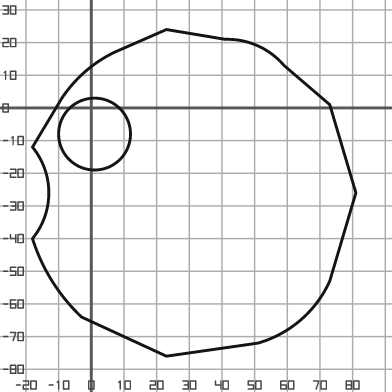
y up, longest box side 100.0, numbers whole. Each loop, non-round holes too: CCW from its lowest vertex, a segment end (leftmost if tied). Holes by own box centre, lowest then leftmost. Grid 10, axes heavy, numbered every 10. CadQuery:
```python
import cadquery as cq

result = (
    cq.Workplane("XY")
    .moveTo(23.0, -76.0)
    .lineTo(51.0, -72.0)
    .threePointArc((64.0, -65.0), (73.0, -53.0))
    .lineTo(81.0, -26.0)
    .lineTo(73.0, 1.0)
    .lineTo(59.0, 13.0)
    .threePointArc((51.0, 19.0), (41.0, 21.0))
    .lineTo(23.0, 24.0)
    .lineTo(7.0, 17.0)
    .threePointArc((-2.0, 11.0), (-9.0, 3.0))
    .lineTo(-18.0, -12.0)
    .threePointArc((-13.0, -26.0), (-18.0, -40.0))
    .threePointArc((-12.0, -53.0), (-3.0, -64.0))
    .close()
    .moveTo(1.0, -8.0)
    .circle(11.0)
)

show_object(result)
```